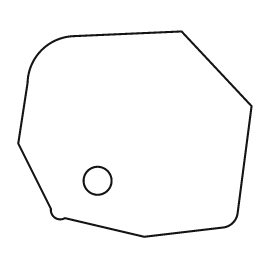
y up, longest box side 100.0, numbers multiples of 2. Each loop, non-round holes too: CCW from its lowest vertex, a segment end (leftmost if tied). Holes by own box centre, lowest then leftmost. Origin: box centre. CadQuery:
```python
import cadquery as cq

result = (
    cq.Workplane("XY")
    .moveTo(4.0, -44.0)
    .lineTo(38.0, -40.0)
    .threePointArc((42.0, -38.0), (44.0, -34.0))
    .lineTo(50.0, 12.0)
    .lineTo(20.0, 44.0)
    .lineTo(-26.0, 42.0)
    .threePointArc((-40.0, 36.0), (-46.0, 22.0))
    .lineTo(-50.0, -4.0)
    .lineTo(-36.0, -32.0)
    .threePointArc((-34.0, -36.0), (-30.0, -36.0))
    .close()
    .moveTo(-16.0, -20.0)
    .circle(6.0)
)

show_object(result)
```